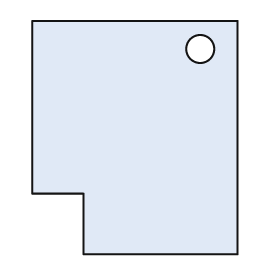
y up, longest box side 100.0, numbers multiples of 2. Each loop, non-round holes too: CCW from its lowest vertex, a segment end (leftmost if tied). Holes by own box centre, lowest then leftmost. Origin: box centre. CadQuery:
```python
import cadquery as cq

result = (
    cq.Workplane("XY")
    .moveTo(-22.0, -50.0)
    .lineTo(44.0, -50.0)
    .lineTo(44.0, 50.0)
    .lineTo(-44.0, 50.0)
    .lineTo(-44.0, -24.0)
    .lineTo(-22.0, -24.0)
    .close()
    .moveTo(28.0, 38.0)
    .circle(6.0)
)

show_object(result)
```